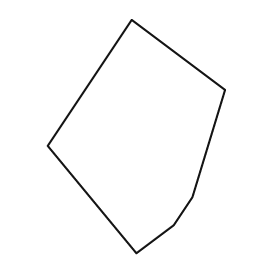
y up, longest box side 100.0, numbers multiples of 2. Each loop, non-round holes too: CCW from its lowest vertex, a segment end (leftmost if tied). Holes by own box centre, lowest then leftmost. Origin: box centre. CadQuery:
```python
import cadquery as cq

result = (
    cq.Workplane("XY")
    .moveTo(0.0, -50.0)
    .lineTo(16.0, -38.0)
    .lineTo(24.0, -26.0)
    .lineTo(38.0, 20.0)
    .lineTo(-2.0, 50.0)
    .lineTo(-38.0, -4.0)
    .close()
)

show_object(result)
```